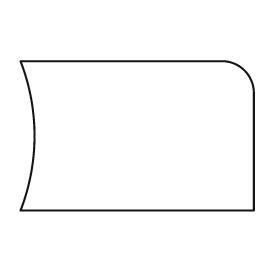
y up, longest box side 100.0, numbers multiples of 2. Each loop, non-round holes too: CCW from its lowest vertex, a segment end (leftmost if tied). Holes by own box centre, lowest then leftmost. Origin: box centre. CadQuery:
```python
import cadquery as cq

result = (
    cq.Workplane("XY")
    .moveTo(-50.0, -32.0)
    .lineTo(50.0, -32.0)
    .lineTo(50.0, 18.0)
    .threePointArc((46.0, 28.0), (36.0, 32.0))
    .lineTo(-50.0, 32.0)
    .threePointArc((-44.0, 0.0), (-50.0, -32.0))
    .close()
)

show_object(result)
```